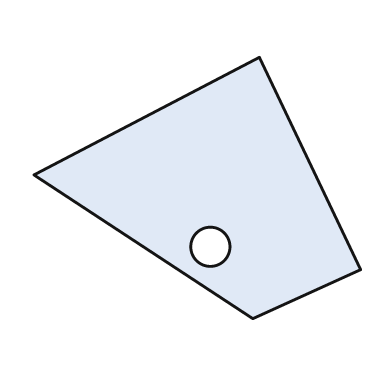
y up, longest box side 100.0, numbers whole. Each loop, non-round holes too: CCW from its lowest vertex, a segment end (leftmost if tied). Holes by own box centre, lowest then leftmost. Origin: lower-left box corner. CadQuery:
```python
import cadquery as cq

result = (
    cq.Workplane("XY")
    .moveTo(67.0, 0.0)
    .lineTo(100.0, 15.0)
    .lineTo(69.0, 80.0)
    .lineTo(0.0, 44.0)
    .close()
    .moveTo(54.0, 22.0)
    .circle(6.0)
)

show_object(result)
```